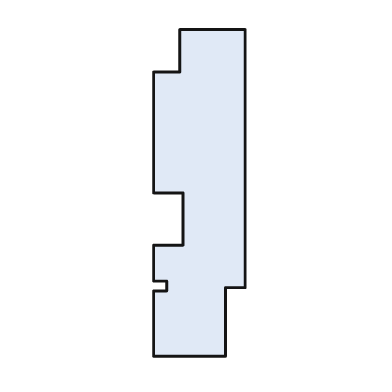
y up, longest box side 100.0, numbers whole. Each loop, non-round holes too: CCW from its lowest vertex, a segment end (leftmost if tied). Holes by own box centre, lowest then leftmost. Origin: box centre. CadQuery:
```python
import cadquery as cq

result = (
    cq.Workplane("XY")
    .moveTo(-14.0, -50.0)
    .lineTo(8.0, -50.0)
    .lineTo(8.0, -29.0)
    .lineTo(14.0, -29.0)
    .lineTo(14.0, 50.0)
    .lineTo(-6.0, 50.0)
    .lineTo(-6.0, 37.0)
    .lineTo(-14.0, 37.0)
    .lineTo(-14.0, 0.0)
    .lineTo(-5.0, 0.0)
    .lineTo(-5.0, -16.0)
    .lineTo(-14.0, -16.0)
    .lineTo(-14.0, -27.0)
    .lineTo(-10.0, -27.0)
    .lineTo(-10.0, -30.0)
    .lineTo(-14.0, -30.0)
    .close()
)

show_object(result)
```